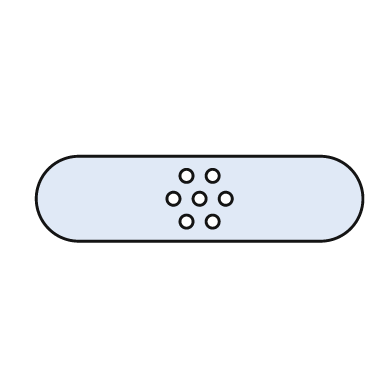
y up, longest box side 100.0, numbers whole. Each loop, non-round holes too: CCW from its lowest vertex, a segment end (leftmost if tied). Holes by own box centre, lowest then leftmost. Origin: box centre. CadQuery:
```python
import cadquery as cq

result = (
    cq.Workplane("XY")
    .moveTo(-37.0, -13.0)
    .lineTo(37.0, -13.0)
    .threePointArc((50.0, 0.0), (37.0, 13.0))
    .lineTo(-37.0, 13.0)
    .threePointArc((-50.0, 0.0), (-37.0, -13.0))
    .close()
    .moveTo(-4.0, -7.0)
    .circle(2.0)
    .moveTo(4.0, -7.0)
    .circle(2.0)
    .moveTo(-8.0, 0.0)
    .circle(2.0)
    .moveTo(0.0, 0.0)
    .circle(2.0)
    .moveTo(8.0, 0.0)
    .circle(2.0)
    .moveTo(-4.0, 7.0)
    .circle(2.0)
    .moveTo(4.0, 7.0)
    .circle(2.0)
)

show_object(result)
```